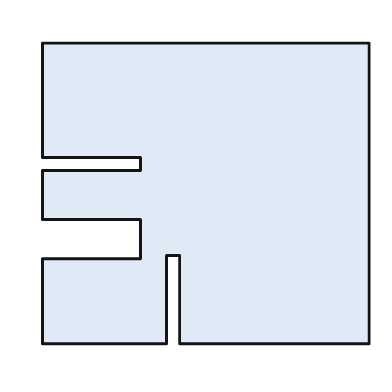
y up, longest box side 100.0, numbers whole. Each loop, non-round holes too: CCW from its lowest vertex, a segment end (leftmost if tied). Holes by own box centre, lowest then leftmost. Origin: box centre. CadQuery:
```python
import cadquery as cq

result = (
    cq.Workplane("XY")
    .moveTo(-50.0, -46.0)
    .lineTo(-12.0, -46.0)
    .lineTo(-12.0, -19.0)
    .lineTo(-8.0, -19.0)
    .lineTo(-8.0, -46.0)
    .lineTo(50.0, -46.0)
    .lineTo(50.0, 46.0)
    .lineTo(-50.0, 46.0)
    .lineTo(-50.0, 11.0)
    .lineTo(-20.0, 11.0)
    .lineTo(-20.0, 7.0)
    .lineTo(-50.0, 7.0)
    .lineTo(-50.0, -8.0)
    .lineTo(-20.0, -8.0)
    .lineTo(-20.0, -20.0)
    .lineTo(-50.0, -20.0)
    .close()
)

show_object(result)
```